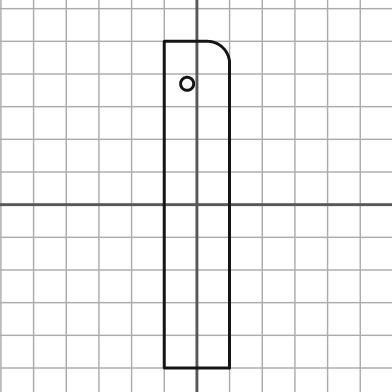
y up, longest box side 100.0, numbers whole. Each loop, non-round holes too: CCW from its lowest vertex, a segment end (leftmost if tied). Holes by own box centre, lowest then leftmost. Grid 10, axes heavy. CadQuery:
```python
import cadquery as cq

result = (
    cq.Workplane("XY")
    .moveTo(-10.0, -50.0)
    .lineTo(10.0, -50.0)
    .lineTo(10.0, 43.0)
    .threePointArc((8.0, 48.0), (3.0, 50.0))
    .lineTo(-10.0, 50.0)
    .close()
    .moveTo(-3.0, 37.0)
    .circle(2.0)
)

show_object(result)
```